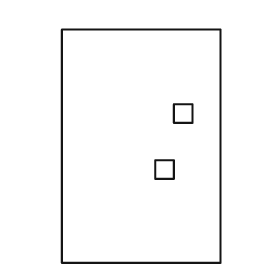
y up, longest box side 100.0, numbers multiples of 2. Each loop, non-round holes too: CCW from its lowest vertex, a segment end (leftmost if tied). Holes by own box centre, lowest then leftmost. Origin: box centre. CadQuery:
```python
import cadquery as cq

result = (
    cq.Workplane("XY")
    .moveTo(-34.0, -50.0)
    .lineTo(34.0, -50.0)
    .lineTo(34.0, 50.0)
    .lineTo(-34.0, 50.0)
    .close()
    .moveTo(6.0, -14.0)
    .lineTo(14.0, -14.0)
    .lineTo(14.0, -6.0)
    .lineTo(6.0, -6.0)
    .close()
    .moveTo(14.0, 10.0)
    .lineTo(22.0, 10.0)
    .lineTo(22.0, 18.0)
    .lineTo(14.0, 18.0)
    .close()
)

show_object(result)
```